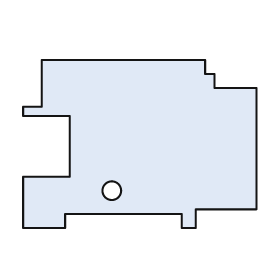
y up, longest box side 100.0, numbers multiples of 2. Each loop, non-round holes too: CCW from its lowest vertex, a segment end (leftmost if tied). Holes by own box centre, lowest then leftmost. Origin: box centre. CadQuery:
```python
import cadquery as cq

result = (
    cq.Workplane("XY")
    .moveTo(-50.0, -36.0)
    .lineTo(-32.0, -36.0)
    .lineTo(-32.0, -30.0)
    .lineTo(18.0, -30.0)
    .lineTo(18.0, -36.0)
    .lineTo(24.0, -36.0)
    .lineTo(24.0, -28.0)
    .lineTo(50.0, -28.0)
    .lineTo(50.0, 24.0)
    .lineTo(32.0, 24.0)
    .lineTo(32.0, 30.0)
    .lineTo(28.0, 30.0)
    .lineTo(28.0, 36.0)
    .lineTo(-42.0, 36.0)
    .lineTo(-42.0, 16.0)
    .lineTo(-50.0, 16.0)
    .lineTo(-50.0, 12.0)
    .lineTo(-30.0, 12.0)
    .lineTo(-30.0, -14.0)
    .lineTo(-50.0, -14.0)
    .close()
    .moveTo(-12.0, -20.0)
    .circle(4.0)
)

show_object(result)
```